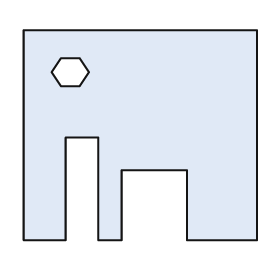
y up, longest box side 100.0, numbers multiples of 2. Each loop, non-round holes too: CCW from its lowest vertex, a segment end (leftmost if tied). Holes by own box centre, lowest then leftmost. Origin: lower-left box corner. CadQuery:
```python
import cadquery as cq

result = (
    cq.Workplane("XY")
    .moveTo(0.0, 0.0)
    .lineTo(18.0, 0.0)
    .lineTo(18.0, 44.0)
    .lineTo(32.0, 44.0)
    .lineTo(32.0, 0.0)
    .lineTo(42.0, 0.0)
    .lineTo(42.0, 30.0)
    .lineTo(70.0, 30.0)
    .lineTo(70.0, 0.0)
    .lineTo(100.0, 0.0)
    .lineTo(100.0, 90.0)
    .lineTo(0.0, 90.0)
    .close()
    .moveTo(16.0, 66.0)
    .lineTo(24.0, 66.0)
    .lineTo(28.0, 72.0)
    .lineTo(24.0, 78.0)
    .lineTo(16.0, 78.0)
    .lineTo(12.0, 72.0)
    .close()
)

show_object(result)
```